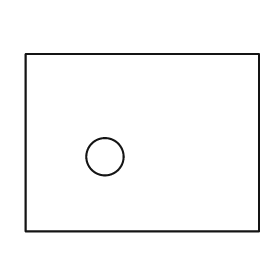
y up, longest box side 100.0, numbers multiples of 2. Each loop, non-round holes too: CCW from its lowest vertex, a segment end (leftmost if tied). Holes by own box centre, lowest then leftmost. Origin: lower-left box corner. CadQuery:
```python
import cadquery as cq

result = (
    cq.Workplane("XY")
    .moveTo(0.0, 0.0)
    .lineTo(100.0, 0.0)
    .lineTo(100.0, 76.0)
    .lineTo(0.0, 76.0)
    .close()
    .moveTo(34.0, 32.0)
    .circle(8.0)
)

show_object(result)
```